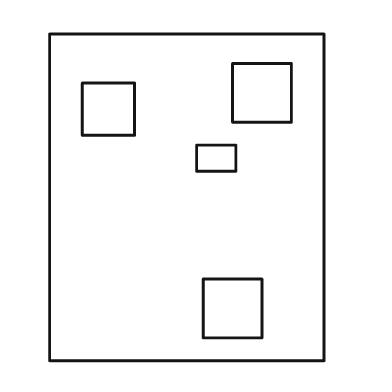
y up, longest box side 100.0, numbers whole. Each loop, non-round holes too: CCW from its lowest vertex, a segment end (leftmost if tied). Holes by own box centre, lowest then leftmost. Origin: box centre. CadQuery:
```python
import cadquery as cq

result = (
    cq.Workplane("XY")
    .moveTo(-42.0, -50.0)
    .lineTo(42.0, -50.0)
    .lineTo(42.0, 50.0)
    .lineTo(-42.0, 50.0)
    .close()
    .moveTo(5.0, -43.0)
    .lineTo(23.0, -43.0)
    .lineTo(23.0, -25.0)
    .lineTo(5.0, -25.0)
    .close()
    .moveTo(3.0, 8.0)
    .lineTo(15.0, 8.0)
    .lineTo(15.0, 16.0)
    .lineTo(3.0, 16.0)
    .close()
    .moveTo(-32.0, 19.0)
    .lineTo(-16.0, 19.0)
    .lineTo(-16.0, 35.0)
    .lineTo(-32.0, 35.0)
    .close()
    .moveTo(14.0, 23.0)
    .lineTo(32.0, 23.0)
    .lineTo(32.0, 41.0)
    .lineTo(14.0, 41.0)
    .close()
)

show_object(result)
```